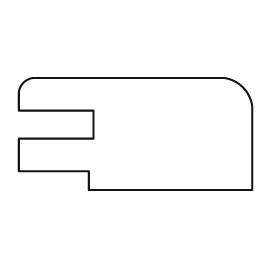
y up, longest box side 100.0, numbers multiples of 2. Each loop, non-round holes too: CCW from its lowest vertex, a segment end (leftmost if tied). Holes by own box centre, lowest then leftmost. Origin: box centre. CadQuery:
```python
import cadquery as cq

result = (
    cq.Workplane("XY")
    .moveTo(-20.0, -24.0)
    .lineTo(50.0, -24.0)
    .lineTo(50.0, 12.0)
    .threePointArc((46.0, 20.0), (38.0, 24.0))
    .lineTo(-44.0, 24.0)
    .threePointArc((-48.0, 22.0), (-50.0, 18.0))
    .lineTo(-50.0, 10.0)
    .lineTo(-18.0, 10.0)
    .lineTo(-18.0, -2.0)
    .lineTo(-50.0, -2.0)
    .lineTo(-50.0, -16.0)
    .lineTo(-20.0, -16.0)
    .close()
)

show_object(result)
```